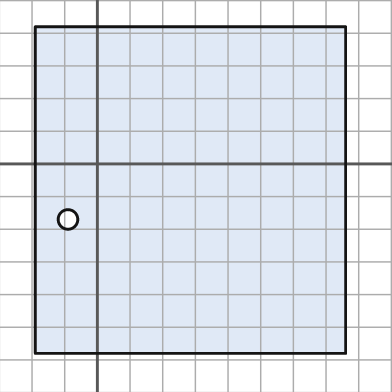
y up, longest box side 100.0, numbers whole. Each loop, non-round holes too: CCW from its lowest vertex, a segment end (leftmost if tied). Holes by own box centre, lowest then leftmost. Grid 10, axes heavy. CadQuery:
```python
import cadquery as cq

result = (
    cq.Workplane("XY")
    .moveTo(-19.0, -58.0)
    .lineTo(76.0, -58.0)
    .lineTo(76.0, 42.0)
    .lineTo(-19.0, 42.0)
    .close()
    .moveTo(-9.0, -17.0)
    .circle(3.0)
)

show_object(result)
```